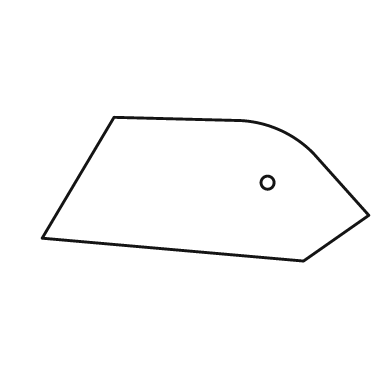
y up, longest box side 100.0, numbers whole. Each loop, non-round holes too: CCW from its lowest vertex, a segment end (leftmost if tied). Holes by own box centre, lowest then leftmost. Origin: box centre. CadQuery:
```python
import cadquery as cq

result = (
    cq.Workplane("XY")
    .moveTo(30.0, -22.0)
    .lineTo(50.0, -8.0)
    .lineTo(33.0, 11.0)
    .threePointArc((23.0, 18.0), (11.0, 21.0))
    .lineTo(-28.0, 22.0)
    .lineTo(-50.0, -15.0)
    .close()
    .moveTo(19.0, 2.0)
    .circle(2.0)
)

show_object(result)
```